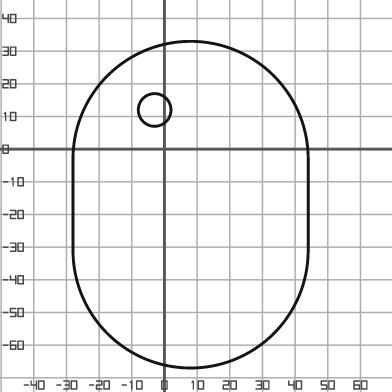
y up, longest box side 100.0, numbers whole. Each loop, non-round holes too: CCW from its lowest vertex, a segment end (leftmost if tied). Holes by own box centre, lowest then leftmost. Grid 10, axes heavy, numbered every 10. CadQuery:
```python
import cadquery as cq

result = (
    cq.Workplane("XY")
    .moveTo(-28.0, -31.0)
    .threePointArc((8.0, -67.0), (44.0, -31.0))
    .lineTo(44.0, -3.0)
    .threePointArc((8.0, 33.0), (-28.0, -3.0))
    .close()
    .moveTo(-3.0, 12.0)
    .circle(5.0)
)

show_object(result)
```